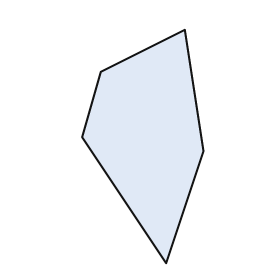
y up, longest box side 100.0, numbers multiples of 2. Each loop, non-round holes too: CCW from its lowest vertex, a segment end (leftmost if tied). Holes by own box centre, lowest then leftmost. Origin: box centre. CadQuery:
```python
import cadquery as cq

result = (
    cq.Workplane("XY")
    .moveTo(10.0, -50.0)
    .lineTo(26.0, -2.0)
    .lineTo(18.0, 50.0)
    .lineTo(-18.0, 32.0)
    .lineTo(-26.0, 4.0)
    .close()
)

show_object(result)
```